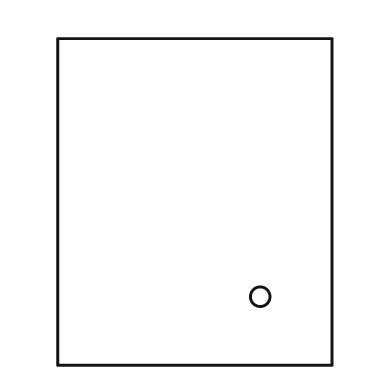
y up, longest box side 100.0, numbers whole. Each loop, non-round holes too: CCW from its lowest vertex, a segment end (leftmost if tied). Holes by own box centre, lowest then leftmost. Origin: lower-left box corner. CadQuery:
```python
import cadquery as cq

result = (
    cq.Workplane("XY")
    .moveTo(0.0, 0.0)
    .lineTo(84.0, 0.0)
    .lineTo(84.0, 100.0)
    .lineTo(0.0, 100.0)
    .close()
    .moveTo(62.0, 21.0)
    .circle(3.0)
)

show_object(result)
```